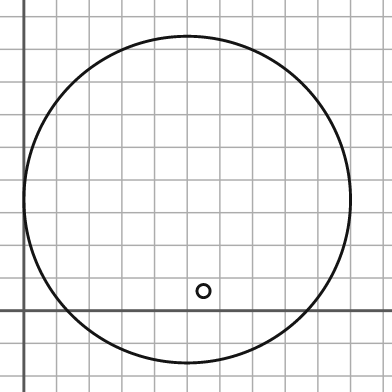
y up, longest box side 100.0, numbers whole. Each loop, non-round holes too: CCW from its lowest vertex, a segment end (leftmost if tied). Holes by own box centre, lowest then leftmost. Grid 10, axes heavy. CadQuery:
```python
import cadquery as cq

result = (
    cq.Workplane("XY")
    .moveTo(50.0, 34.0)
    .circle(50.0)
    .moveTo(55.0, 6.0)
    .circle(2.0)
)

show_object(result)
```